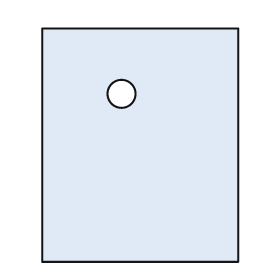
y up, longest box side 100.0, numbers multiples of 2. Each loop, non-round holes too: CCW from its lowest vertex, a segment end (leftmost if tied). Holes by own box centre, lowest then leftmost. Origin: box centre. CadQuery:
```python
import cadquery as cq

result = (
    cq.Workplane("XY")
    .moveTo(-42.0, -50.0)
    .lineTo(42.0, -50.0)
    .lineTo(42.0, 50.0)
    .lineTo(-42.0, 50.0)
    .close()
    .moveTo(-8.0, 22.0)
    .circle(6.0)
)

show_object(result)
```